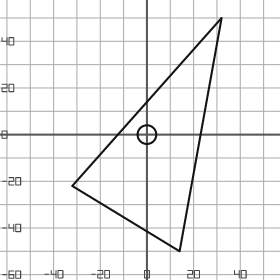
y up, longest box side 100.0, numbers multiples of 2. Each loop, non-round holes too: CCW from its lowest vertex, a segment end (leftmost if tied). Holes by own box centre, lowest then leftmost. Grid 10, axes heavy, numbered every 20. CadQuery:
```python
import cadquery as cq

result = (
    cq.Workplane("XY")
    .moveTo(14.0, -50.0)
    .lineTo(32.0, 50.0)
    .lineTo(-32.0, -22.0)
    .close()
    .moveTo(0.0, 0.0)
    .circle(4.0)
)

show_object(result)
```